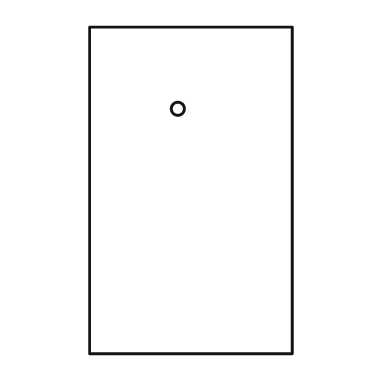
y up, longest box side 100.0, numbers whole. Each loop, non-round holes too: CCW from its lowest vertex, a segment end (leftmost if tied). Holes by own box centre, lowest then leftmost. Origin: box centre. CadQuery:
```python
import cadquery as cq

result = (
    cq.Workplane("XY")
    .moveTo(-31.0, -50.0)
    .lineTo(31.0, -50.0)
    .lineTo(31.0, 50.0)
    .lineTo(-31.0, 50.0)
    .close()
    .moveTo(-4.0, 25.0)
    .circle(2.0)
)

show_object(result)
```